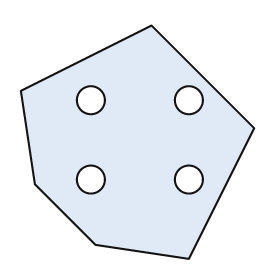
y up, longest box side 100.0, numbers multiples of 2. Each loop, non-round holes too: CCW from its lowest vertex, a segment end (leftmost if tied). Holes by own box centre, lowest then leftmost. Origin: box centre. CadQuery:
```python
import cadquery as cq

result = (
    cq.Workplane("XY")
    .moveTo(22.0, -50.0)
    .lineTo(50.0, 6.0)
    .lineTo(6.0, 50.0)
    .lineTo(-50.0, 22.0)
    .lineTo(-44.0, -18.0)
    .lineTo(-18.0, -44.0)
    .close()
    .moveTo(-20.0, -16.0)
    .circle(6.0)
    .moveTo(22.0, -16.0)
    .circle(6.0)
    .moveTo(-20.0, 18.0)
    .circle(6.0)
    .moveTo(22.0, 18.0)
    .circle(6.0)
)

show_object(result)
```